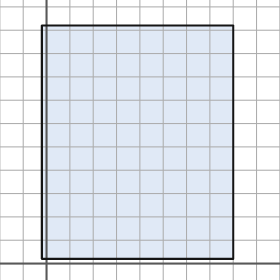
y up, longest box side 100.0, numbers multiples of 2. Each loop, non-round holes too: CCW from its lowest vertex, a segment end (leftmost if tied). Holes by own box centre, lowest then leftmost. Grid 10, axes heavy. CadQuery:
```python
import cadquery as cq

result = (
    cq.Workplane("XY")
    .moveTo(-2.0, 2.0)
    .lineTo(80.0, 2.0)
    .lineTo(80.0, 102.0)
    .lineTo(-2.0, 102.0)
    .close()
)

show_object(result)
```